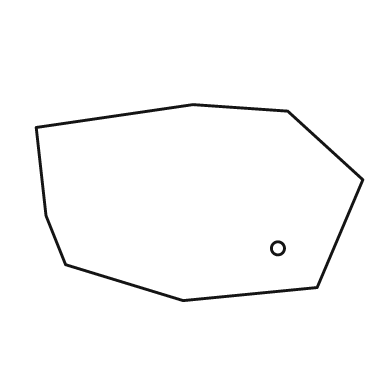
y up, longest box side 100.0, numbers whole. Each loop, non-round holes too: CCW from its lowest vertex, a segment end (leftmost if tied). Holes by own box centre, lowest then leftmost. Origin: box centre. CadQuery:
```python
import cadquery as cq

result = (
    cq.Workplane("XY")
    .moveTo(-5.0, -30.0)
    .lineTo(36.0, -26.0)
    .lineTo(50.0, 7.0)
    .lineTo(27.0, 28.0)
    .lineTo(-2.0, 30.0)
    .lineTo(-50.0, 23.0)
    .lineTo(-47.0, -4.0)
    .lineTo(-41.0, -19.0)
    .close()
    .moveTo(24.0, -14.0)
    .circle(2.0)
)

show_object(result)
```